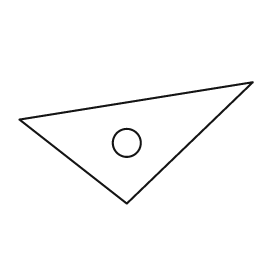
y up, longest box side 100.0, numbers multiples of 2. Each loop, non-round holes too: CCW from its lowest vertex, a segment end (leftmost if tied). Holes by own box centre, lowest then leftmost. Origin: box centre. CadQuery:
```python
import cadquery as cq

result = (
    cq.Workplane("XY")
    .moveTo(-4.0, -26.0)
    .lineTo(50.0, 26.0)
    .lineTo(-50.0, 10.0)
    .close()
    .moveTo(-4.0, 0.0)
    .circle(6.0)
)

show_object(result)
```